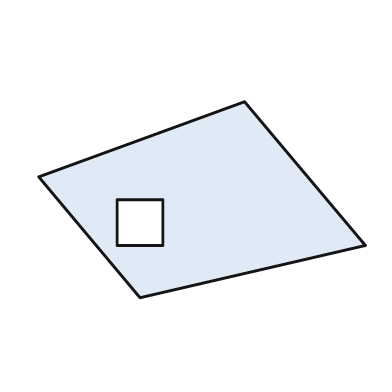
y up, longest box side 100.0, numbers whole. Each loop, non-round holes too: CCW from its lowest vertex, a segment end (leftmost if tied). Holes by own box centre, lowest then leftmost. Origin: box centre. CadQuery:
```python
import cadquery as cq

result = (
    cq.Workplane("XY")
    .moveTo(-19.0, -30.0)
    .lineTo(50.0, -14.0)
    .lineTo(13.0, 30.0)
    .lineTo(-50.0, 7.0)
    .close()
    .moveTo(-26.0, -14.0)
    .lineTo(-12.0, -14.0)
    .lineTo(-12.0, 0.0)
    .lineTo(-26.0, 0.0)
    .close()
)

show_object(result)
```